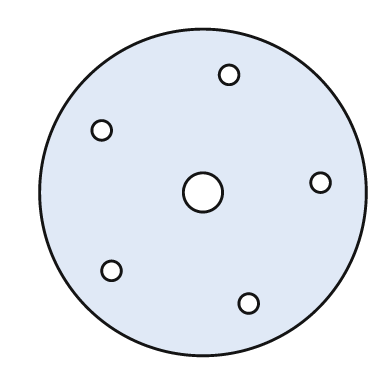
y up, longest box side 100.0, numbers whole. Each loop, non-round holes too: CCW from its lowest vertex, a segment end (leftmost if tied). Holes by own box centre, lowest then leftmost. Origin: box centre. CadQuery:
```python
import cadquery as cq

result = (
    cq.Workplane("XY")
    .moveTo(0.0, 0.0)
    .circle(50.0)
    .moveTo(14.0, -34.0)
    .circle(3.0)
    .moveTo(-28.0, -24.0)
    .circle(3.0)
    .moveTo(0.0, 0.0)
    .circle(6.0)
    .moveTo(36.0, 3.0)
    .circle(3.0)
    .moveTo(-31.0, 19.0)
    .circle(3.0)
    .moveTo(8.0, 36.0)
    .circle(3.0)
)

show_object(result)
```